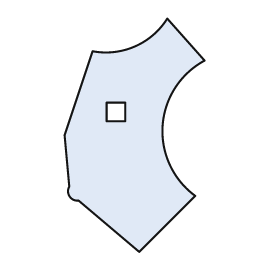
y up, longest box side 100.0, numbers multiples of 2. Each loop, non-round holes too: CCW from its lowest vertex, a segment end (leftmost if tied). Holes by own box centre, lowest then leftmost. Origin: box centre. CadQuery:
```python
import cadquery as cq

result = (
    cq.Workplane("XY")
    .moveTo(2.0, -50.0)
    .lineTo(26.0, -26.0)
    .threePointArc((12.0, 4.0), (30.0, 32.0))
    .lineTo(14.0, 50.0)
    .threePointArc((0.0, 38.0), (-18.0, 36.0))
    .lineTo(-30.0, 0.0)
    .lineTo(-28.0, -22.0)
    .threePointArc((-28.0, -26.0), (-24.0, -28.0))
    .close()
    .moveTo(-12.0, 6.0)
    .lineTo(-4.0, 6.0)
    .lineTo(-4.0, 14.0)
    .lineTo(-12.0, 14.0)
    .close()
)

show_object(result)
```